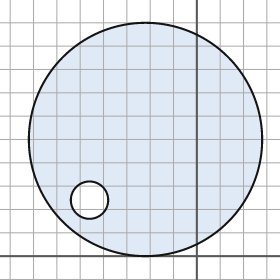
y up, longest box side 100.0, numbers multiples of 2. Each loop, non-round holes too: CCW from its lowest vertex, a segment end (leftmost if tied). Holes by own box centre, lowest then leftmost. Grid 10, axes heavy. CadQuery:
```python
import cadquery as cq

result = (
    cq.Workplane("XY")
    .moveTo(-22.0, 50.0)
    .circle(50.0)
    .moveTo(-46.0, 24.0)
    .circle(8.0)
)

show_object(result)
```